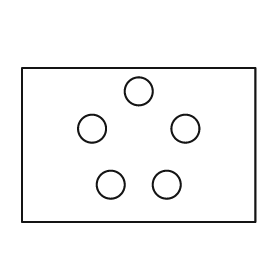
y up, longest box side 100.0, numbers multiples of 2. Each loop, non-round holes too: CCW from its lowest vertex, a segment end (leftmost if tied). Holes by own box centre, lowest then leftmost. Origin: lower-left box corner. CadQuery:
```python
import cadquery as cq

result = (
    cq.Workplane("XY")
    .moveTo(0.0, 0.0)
    .lineTo(100.0, 0.0)
    .lineTo(100.0, 66.0)
    .lineTo(0.0, 66.0)
    .close()
    .moveTo(38.0, 16.0)
    .circle(6.0)
    .moveTo(62.0, 16.0)
    .circle(6.0)
    .moveTo(30.0, 40.0)
    .circle(6.0)
    .moveTo(70.0, 40.0)
    .circle(6.0)
    .moveTo(50.0, 56.0)
    .circle(6.0)
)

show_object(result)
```